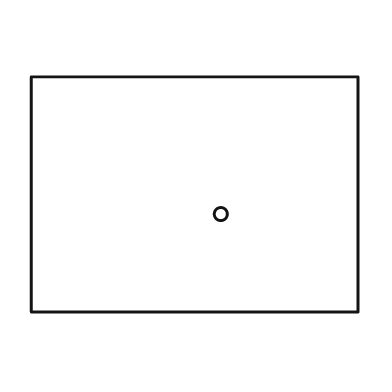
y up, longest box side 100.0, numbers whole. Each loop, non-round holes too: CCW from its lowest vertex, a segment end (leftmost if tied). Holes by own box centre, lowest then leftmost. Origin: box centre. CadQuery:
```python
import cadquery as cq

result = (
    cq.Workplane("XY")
    .moveTo(-50.0, -36.0)
    .lineTo(50.0, -36.0)
    .lineTo(50.0, 36.0)
    .lineTo(-50.0, 36.0)
    .close()
    .moveTo(8.0, -6.0)
    .circle(2.0)
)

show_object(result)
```